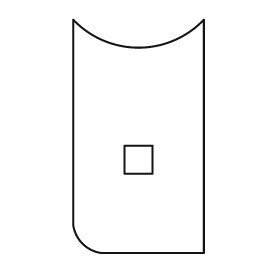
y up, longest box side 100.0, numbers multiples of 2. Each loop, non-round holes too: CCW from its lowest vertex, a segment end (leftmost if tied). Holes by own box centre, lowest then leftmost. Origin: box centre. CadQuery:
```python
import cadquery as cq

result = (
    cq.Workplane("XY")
    .moveTo(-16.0, -50.0)
    .lineTo(28.0, -50.0)
    .lineTo(28.0, 50.0)
    .threePointArc((0.0, 38.0), (-28.0, 50.0))
    .lineTo(-28.0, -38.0)
    .threePointArc((-24.0, -46.0), (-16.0, -50.0))
    .close()
    .moveTo(-6.0, -16.0)
    .lineTo(6.0, -16.0)
    .lineTo(6.0, -4.0)
    .lineTo(-6.0, -4.0)
    .close()
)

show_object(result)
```